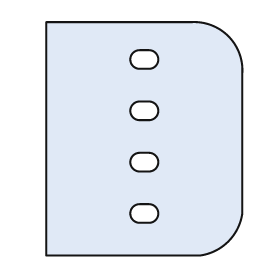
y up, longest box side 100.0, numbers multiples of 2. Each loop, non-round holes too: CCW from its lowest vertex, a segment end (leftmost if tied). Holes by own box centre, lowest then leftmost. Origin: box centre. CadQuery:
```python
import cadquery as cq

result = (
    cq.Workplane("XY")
    .moveTo(-42.0, -50.0)
    .lineTo(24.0, -50.0)
    .threePointArc((36.0, -44.0), (42.0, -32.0))
    .lineTo(42.0, 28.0)
    .threePointArc((36.0, 44.0), (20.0, 50.0))
    .lineTo(-42.0, 50.0)
    .close()
    .moveTo(-2.0, -36.0)
    .lineTo(2.0, -36.0)
    .threePointArc((6.0, -32.0), (2.0, -28.0))
    .lineTo(-2.0, -28.0)
    .threePointArc((-6.0, -32.0), (-2.0, -36.0))
    .close()
    .moveTo(-2.0, -14.0)
    .lineTo(2.0, -14.0)
    .threePointArc((6.0, -10.0), (2.0, -6.0))
    .lineTo(-2.0, -6.0)
    .threePointArc((-6.0, -10.0), (-2.0, -14.0))
    .close()
    .moveTo(-2.0, 8.0)
    .lineTo(2.0, 8.0)
    .threePointArc((6.0, 12.0), (2.0, 16.0))
    .lineTo(-2.0, 16.0)
    .threePointArc((-6.0, 12.0), (-2.0, 8.0))
    .close()
    .moveTo(-2.0, 30.0)
    .lineTo(2.0, 30.0)
    .threePointArc((6.0, 34.0), (2.0, 38.0))
    .lineTo(-2.0, 38.0)
    .threePointArc((-6.0, 34.0), (-2.0, 30.0))
    .close()
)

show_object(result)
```